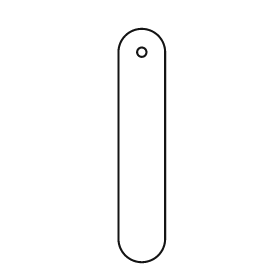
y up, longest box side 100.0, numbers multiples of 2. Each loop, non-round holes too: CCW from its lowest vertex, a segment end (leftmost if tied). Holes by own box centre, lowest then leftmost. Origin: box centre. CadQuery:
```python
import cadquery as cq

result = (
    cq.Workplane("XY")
    .moveTo(-10.0, -40.0)
    .threePointArc((0.0, -50.0), (10.0, -40.0))
    .lineTo(10.0, 40.0)
    .threePointArc((0.0, 50.0), (-10.0, 40.0))
    .close()
    .moveTo(0.0, 40.0)
    .circle(2.0)
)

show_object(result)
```